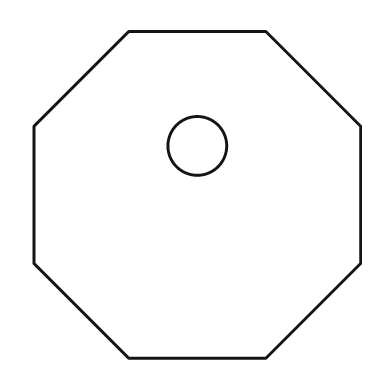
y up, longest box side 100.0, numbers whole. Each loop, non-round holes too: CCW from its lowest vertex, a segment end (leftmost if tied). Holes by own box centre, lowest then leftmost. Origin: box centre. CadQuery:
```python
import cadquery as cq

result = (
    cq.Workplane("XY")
    .moveTo(-21.0, -50.0)
    .lineTo(21.0, -50.0)
    .lineTo(50.0, -21.0)
    .lineTo(50.0, 21.0)
    .lineTo(21.0, 50.0)
    .lineTo(-21.0, 50.0)
    .lineTo(-50.0, 21.0)
    .lineTo(-50.0, -21.0)
    .close()
    .moveTo(0.0, 15.0)
    .circle(9.0)
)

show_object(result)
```